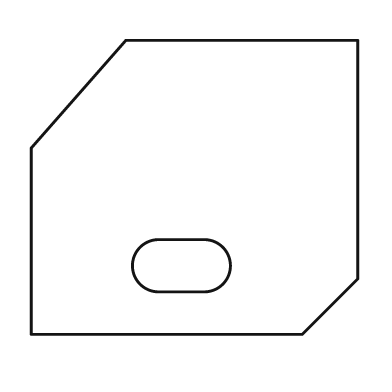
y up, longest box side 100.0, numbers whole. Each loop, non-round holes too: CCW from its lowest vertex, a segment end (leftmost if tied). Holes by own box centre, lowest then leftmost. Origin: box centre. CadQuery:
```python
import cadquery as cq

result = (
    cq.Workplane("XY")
    .moveTo(-50.0, -45.0)
    .lineTo(33.0, -45.0)
    .lineTo(50.0, -28.0)
    .lineTo(50.0, 45.0)
    .lineTo(-21.0, 45.0)
    .lineTo(-50.0, 12.0)
    .close()
    .moveTo(-11.0, -32.0)
    .lineTo(3.0, -32.0)
    .threePointArc((11.0, -24.0), (3.0, -16.0))
    .lineTo(-11.0, -16.0)
    .threePointArc((-19.0, -24.0), (-11.0, -32.0))
    .close()
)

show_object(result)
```